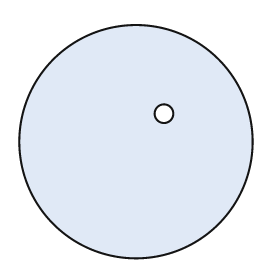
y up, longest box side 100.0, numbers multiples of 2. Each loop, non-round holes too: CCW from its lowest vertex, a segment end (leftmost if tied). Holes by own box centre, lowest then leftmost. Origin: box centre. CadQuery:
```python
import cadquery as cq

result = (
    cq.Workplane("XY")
    .moveTo(0.0, 0.0)
    .circle(50.0)
    .moveTo(12.0, 12.0)
    .circle(4.0)
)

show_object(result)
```